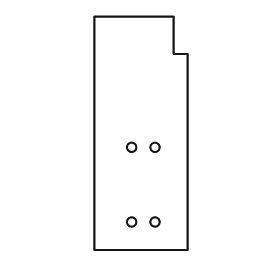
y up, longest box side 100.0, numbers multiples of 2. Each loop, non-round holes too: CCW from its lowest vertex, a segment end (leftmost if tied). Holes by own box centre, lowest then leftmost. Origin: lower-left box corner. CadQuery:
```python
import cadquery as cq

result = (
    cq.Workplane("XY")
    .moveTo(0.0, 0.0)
    .lineTo(40.0, 0.0)
    .lineTo(40.0, 84.0)
    .lineTo(34.0, 84.0)
    .lineTo(34.0, 100.0)
    .lineTo(0.0, 100.0)
    .close()
    .moveTo(16.0, 12.0)
    .circle(2.0)
    .moveTo(26.0, 12.0)
    .circle(2.0)
    .moveTo(16.0, 44.0)
    .circle(2.0)
    .moveTo(26.0, 44.0)
    .circle(2.0)
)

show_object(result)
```